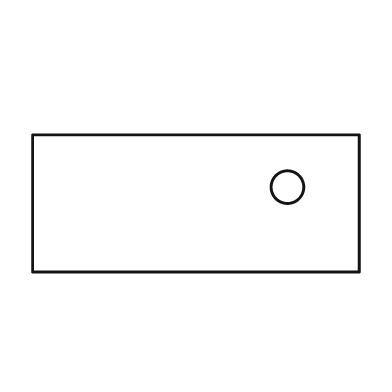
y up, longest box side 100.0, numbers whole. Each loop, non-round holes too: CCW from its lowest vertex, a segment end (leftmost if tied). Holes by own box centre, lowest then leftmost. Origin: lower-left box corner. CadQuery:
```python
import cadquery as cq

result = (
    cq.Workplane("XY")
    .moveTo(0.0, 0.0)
    .lineTo(100.0, 0.0)
    .lineTo(100.0, 42.0)
    .lineTo(0.0, 42.0)
    .close()
    .moveTo(78.0, 26.0)
    .circle(5.0)
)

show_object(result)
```